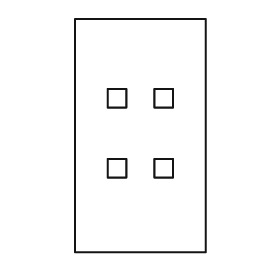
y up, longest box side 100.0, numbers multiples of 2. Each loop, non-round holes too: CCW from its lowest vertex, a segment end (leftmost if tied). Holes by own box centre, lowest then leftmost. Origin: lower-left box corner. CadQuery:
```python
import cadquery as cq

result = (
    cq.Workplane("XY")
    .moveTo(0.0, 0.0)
    .lineTo(56.0, 0.0)
    .lineTo(56.0, 100.0)
    .lineTo(0.0, 100.0)
    .close()
    .moveTo(14.0, 32.0)
    .lineTo(22.0, 32.0)
    .lineTo(22.0, 40.0)
    .lineTo(14.0, 40.0)
    .close()
    .moveTo(34.0, 32.0)
    .lineTo(42.0, 32.0)
    .lineTo(42.0, 40.0)
    .lineTo(34.0, 40.0)
    .close()
    .moveTo(14.0, 62.0)
    .lineTo(22.0, 62.0)
    .lineTo(22.0, 70.0)
    .lineTo(14.0, 70.0)
    .close()
    .moveTo(34.0, 62.0)
    .lineTo(42.0, 62.0)
    .lineTo(42.0, 70.0)
    .lineTo(34.0, 70.0)
    .close()
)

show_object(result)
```